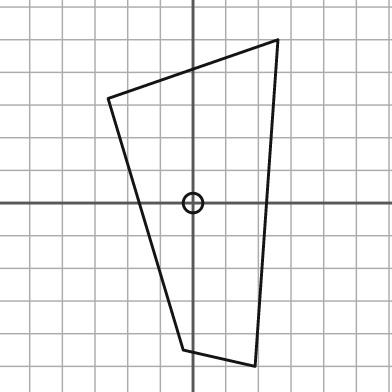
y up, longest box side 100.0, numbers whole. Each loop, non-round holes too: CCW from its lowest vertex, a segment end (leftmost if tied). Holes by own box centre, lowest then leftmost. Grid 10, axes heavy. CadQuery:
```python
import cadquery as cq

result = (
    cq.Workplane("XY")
    .moveTo(19.0, -50.0)
    .lineTo(26.0, 50.0)
    .lineTo(-26.0, 32.0)
    .lineTo(-3.0, -45.0)
    .close()
    .moveTo(0.0, 0.0)
    .circle(3.0)
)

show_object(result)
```